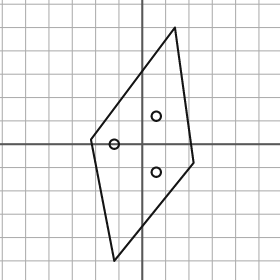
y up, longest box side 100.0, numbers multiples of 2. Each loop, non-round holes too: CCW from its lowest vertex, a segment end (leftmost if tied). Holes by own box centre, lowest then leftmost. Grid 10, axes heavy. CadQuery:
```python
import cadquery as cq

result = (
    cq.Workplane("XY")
    .moveTo(-12.0, -50.0)
    .lineTo(22.0, -8.0)
    .lineTo(14.0, 50.0)
    .lineTo(-22.0, 2.0)
    .close()
    .moveTo(6.0, -12.0)
    .circle(2.0)
    .moveTo(-12.0, 0.0)
    .circle(2.0)
    .moveTo(6.0, 12.0)
    .circle(2.0)
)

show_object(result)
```